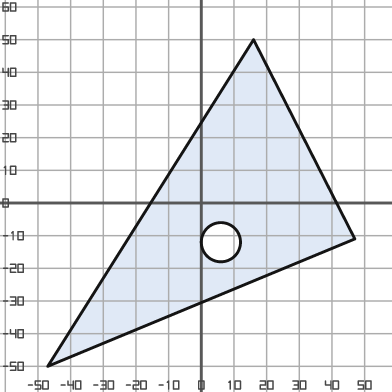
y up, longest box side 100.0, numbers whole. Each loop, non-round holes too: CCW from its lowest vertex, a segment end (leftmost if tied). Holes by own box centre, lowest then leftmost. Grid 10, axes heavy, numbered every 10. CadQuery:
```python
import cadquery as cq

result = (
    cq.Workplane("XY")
    .moveTo(-47.0, -50.0)
    .lineTo(47.0, -11.0)
    .lineTo(16.0, 50.0)
    .close()
    .moveTo(6.0, -12.0)
    .circle(6.0)
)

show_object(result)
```